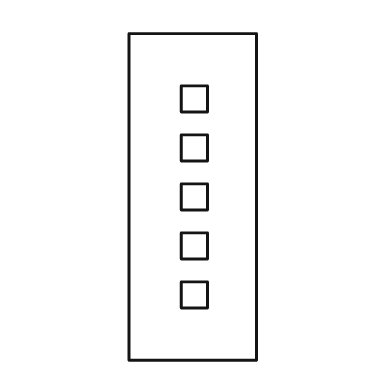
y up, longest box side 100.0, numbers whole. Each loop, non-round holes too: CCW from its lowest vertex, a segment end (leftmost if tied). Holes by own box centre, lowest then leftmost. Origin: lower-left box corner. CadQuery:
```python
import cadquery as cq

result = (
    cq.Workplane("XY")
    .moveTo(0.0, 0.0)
    .lineTo(39.0, 0.0)
    .lineTo(39.0, 100.0)
    .lineTo(0.0, 100.0)
    .close()
    .moveTo(16.0, 16.0)
    .lineTo(24.0, 16.0)
    .lineTo(24.0, 24.0)
    .lineTo(16.0, 24.0)
    .close()
    .moveTo(16.0, 31.0)
    .lineTo(24.0, 31.0)
    .lineTo(24.0, 39.0)
    .lineTo(16.0, 39.0)
    .close()
    .moveTo(16.0, 46.0)
    .lineTo(24.0, 46.0)
    .lineTo(24.0, 54.0)
    .lineTo(16.0, 54.0)
    .close()
    .moveTo(16.0, 61.0)
    .lineTo(24.0, 61.0)
    .lineTo(24.0, 69.0)
    .lineTo(16.0, 69.0)
    .close()
    .moveTo(16.0, 76.0)
    .lineTo(24.0, 76.0)
    .lineTo(24.0, 84.0)
    .lineTo(16.0, 84.0)
    .close()
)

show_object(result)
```